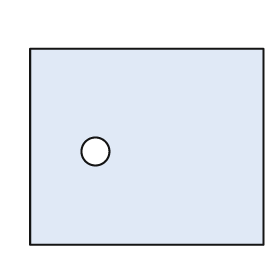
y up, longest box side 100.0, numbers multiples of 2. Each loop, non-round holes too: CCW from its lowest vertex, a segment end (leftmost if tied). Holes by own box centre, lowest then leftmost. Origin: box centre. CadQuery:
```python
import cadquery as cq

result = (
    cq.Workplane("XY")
    .moveTo(-50.0, -42.0)
    .lineTo(50.0, -42.0)
    .lineTo(50.0, 42.0)
    .lineTo(-50.0, 42.0)
    .close()
    .moveTo(-22.0, -2.0)
    .circle(6.0)
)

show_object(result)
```